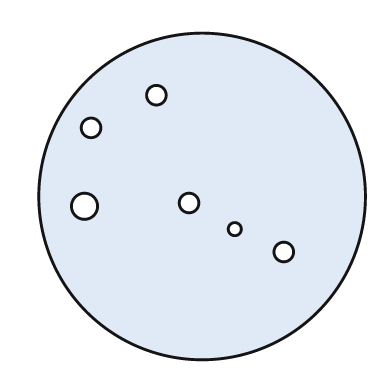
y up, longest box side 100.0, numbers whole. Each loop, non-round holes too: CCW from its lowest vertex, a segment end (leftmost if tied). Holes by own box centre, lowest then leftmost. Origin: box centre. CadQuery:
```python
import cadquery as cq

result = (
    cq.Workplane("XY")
    .moveTo(0.0, 0.0)
    .circle(50.0)
    .moveTo(25.0, -17.0)
    .circle(3.0)
    .moveTo(10.0, -10.0)
    .circle(2.0)
    .moveTo(-36.0, -3.0)
    .circle(4.0)
    .moveTo(-4.0, -2.0)
    .circle(3.0)
    .moveTo(-34.0, 21.0)
    .circle(3.0)
    .moveTo(-14.0, 31.0)
    .circle(3.0)
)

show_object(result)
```